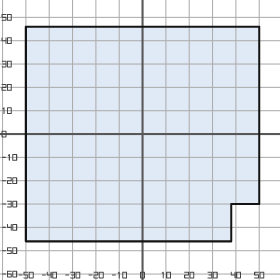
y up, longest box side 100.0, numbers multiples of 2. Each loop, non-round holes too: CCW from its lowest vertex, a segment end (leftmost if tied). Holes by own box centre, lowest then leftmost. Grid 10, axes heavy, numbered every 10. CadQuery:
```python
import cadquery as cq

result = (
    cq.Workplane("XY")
    .moveTo(-50.0, -46.0)
    .lineTo(38.0, -46.0)
    .lineTo(38.0, -30.0)
    .lineTo(50.0, -30.0)
    .lineTo(50.0, 46.0)
    .lineTo(-50.0, 46.0)
    .close()
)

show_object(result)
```